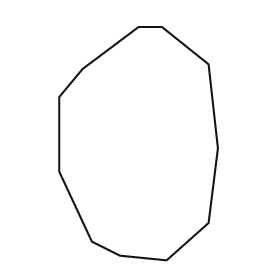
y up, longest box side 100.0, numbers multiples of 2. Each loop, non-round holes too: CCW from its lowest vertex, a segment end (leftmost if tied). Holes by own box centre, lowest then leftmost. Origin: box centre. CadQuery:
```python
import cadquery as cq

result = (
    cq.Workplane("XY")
    .moveTo(12.0, -50.0)
    .lineTo(30.0, -34.0)
    .lineTo(34.0, -2.0)
    .lineTo(30.0, 34.0)
    .lineTo(10.0, 50.0)
    .lineTo(0.0, 50.0)
    .lineTo(-24.0, 32.0)
    .lineTo(-34.0, 20.0)
    .lineTo(-34.0, -12.0)
    .lineTo(-20.0, -42.0)
    .lineTo(-8.0, -48.0)
    .close()
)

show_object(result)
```